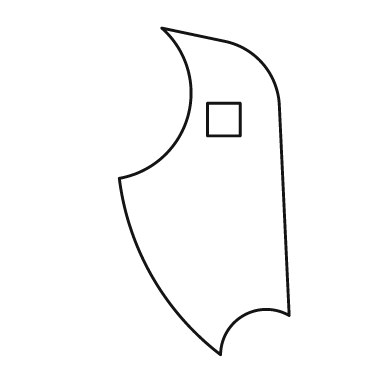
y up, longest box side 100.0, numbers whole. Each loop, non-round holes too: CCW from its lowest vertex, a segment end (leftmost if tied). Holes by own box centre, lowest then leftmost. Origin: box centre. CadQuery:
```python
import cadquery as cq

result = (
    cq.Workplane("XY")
    .moveTo(5.0, -50.0)
    .threePointArc((12.0, -38.0), (26.0, -38.0))
    .lineTo(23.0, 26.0)
    .threePointArc((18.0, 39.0), (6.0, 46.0))
    .lineTo(-13.0, 50.0)
    .threePointArc((-5.0, 23.0), (-26.0, 4.0))
    .threePointArc((-16.0, -26.0), (5.0, -50.0))
    .close()
    .moveTo(1.0, 17.0)
    .lineTo(11.0, 17.0)
    .lineTo(11.0, 27.0)
    .lineTo(1.0, 27.0)
    .close()
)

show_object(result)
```